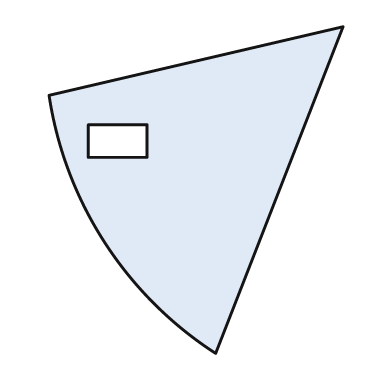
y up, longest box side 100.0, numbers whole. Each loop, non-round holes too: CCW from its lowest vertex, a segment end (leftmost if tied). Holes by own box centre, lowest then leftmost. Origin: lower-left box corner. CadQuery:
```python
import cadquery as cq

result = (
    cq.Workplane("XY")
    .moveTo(51.0, 0.0)
    .lineTo(90.0, 100.0)
    .lineTo(0.0, 79.0)
    .threePointArc((17.0, 34.0), (51.0, 0.0))
    .close()
    .moveTo(12.0, 60.0)
    .lineTo(30.0, 60.0)
    .lineTo(30.0, 70.0)
    .lineTo(12.0, 70.0)
    .close()
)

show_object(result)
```